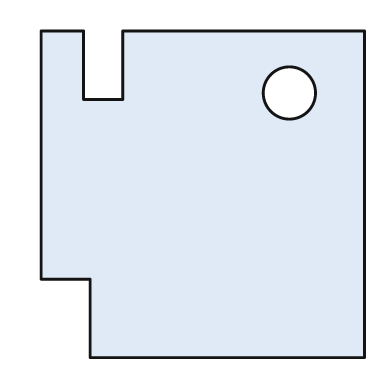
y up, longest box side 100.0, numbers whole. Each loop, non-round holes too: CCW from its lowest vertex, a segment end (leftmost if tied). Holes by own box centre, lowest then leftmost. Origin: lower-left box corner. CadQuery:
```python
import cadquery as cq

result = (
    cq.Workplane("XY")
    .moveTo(15.0, 0.0)
    .lineTo(99.0, 0.0)
    .lineTo(99.0, 100.0)
    .lineTo(25.0, 100.0)
    .lineTo(25.0, 79.0)
    .lineTo(13.0, 79.0)
    .lineTo(13.0, 100.0)
    .lineTo(0.0, 100.0)
    .lineTo(0.0, 24.0)
    .lineTo(15.0, 24.0)
    .close()
    .moveTo(76.0, 81.0)
    .circle(8.0)
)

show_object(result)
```